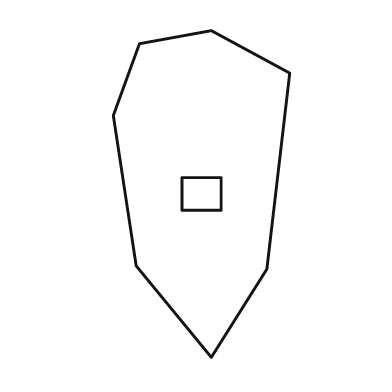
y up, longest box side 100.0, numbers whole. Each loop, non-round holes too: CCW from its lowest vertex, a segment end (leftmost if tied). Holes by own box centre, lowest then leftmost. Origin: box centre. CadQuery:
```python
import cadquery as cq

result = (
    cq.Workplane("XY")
    .moveTo(3.0, -50.0)
    .lineTo(20.0, -23.0)
    .lineTo(27.0, 37.0)
    .lineTo(3.0, 50.0)
    .lineTo(-19.0, 46.0)
    .lineTo(-27.0, 24.0)
    .lineTo(-20.0, -22.0)
    .close()
    .moveTo(-6.0, -5.0)
    .lineTo(6.0, -5.0)
    .lineTo(6.0, 5.0)
    .lineTo(-6.0, 5.0)
    .close()
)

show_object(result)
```